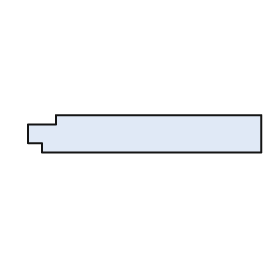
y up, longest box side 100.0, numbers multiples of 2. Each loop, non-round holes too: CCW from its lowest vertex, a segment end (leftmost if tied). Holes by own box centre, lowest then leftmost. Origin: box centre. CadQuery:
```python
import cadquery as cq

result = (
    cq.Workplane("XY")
    .moveTo(-44.0, -8.0)
    .lineTo(50.0, -8.0)
    .lineTo(50.0, 8.0)
    .lineTo(-38.0, 8.0)
    .lineTo(-38.0, 4.0)
    .lineTo(-50.0, 4.0)
    .lineTo(-50.0, -4.0)
    .lineTo(-44.0, -4.0)
    .close()
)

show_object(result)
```